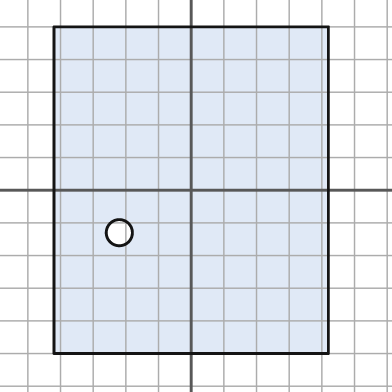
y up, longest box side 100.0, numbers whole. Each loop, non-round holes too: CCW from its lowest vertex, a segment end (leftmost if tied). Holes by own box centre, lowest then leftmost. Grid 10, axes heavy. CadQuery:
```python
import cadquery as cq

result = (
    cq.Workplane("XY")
    .moveTo(-42.0, -50.0)
    .lineTo(42.0, -50.0)
    .lineTo(42.0, 50.0)
    .lineTo(-42.0, 50.0)
    .close()
    .moveTo(-22.0, -13.0)
    .circle(4.0)
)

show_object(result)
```